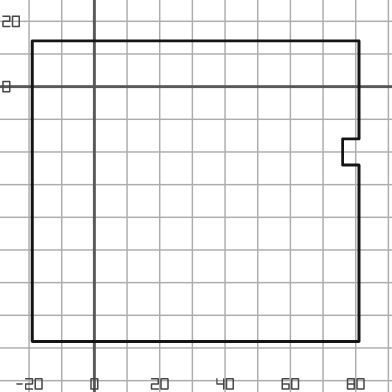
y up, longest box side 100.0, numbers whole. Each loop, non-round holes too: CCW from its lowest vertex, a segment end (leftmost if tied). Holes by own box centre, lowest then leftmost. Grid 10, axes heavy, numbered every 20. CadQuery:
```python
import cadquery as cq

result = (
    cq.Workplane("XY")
    .moveTo(-19.0, -78.0)
    .lineTo(81.0, -78.0)
    .lineTo(81.0, -24.0)
    .lineTo(76.0, -24.0)
    .lineTo(76.0, -16.0)
    .lineTo(81.0, -16.0)
    .lineTo(81.0, 14.0)
    .lineTo(-19.0, 14.0)
    .close()
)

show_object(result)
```